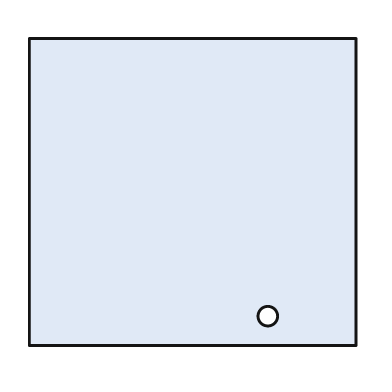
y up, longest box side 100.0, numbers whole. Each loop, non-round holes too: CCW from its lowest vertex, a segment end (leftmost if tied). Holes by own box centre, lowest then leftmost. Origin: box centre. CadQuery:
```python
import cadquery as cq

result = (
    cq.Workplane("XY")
    .moveTo(-50.0, -47.0)
    .lineTo(50.0, -47.0)
    .lineTo(50.0, 47.0)
    .lineTo(-50.0, 47.0)
    .close()
    .moveTo(23.0, -38.0)
    .circle(3.0)
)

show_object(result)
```